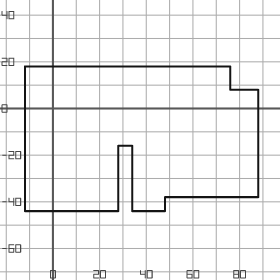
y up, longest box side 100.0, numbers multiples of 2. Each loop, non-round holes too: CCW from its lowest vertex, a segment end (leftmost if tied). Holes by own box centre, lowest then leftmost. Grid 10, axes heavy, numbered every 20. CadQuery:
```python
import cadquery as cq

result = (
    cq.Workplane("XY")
    .moveTo(-12.0, -44.0)
    .lineTo(28.0, -44.0)
    .lineTo(28.0, -16.0)
    .lineTo(34.0, -16.0)
    .lineTo(34.0, -44.0)
    .lineTo(48.0, -44.0)
    .lineTo(48.0, -38.0)
    .lineTo(88.0, -38.0)
    .lineTo(88.0, 8.0)
    .lineTo(76.0, 8.0)
    .lineTo(76.0, 18.0)
    .lineTo(-12.0, 18.0)
    .close()
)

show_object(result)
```